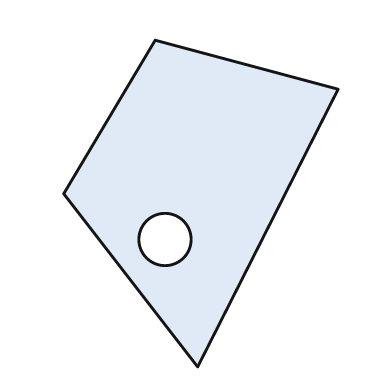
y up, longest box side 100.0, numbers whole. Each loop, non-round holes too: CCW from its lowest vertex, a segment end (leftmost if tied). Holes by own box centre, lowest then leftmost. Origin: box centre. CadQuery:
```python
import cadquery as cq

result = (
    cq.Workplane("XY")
    .moveTo(-1.0, -50.0)
    .lineTo(42.0, 35.0)
    .lineTo(-14.0, 50.0)
    .lineTo(-42.0, 3.0)
    .close()
    .moveTo(-11.0, -11.0)
    .circle(8.0)
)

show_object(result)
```